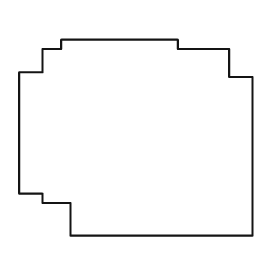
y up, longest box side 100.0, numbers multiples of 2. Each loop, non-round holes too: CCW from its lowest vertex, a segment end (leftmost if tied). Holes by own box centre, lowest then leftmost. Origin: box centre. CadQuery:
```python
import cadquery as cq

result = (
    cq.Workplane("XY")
    .moveTo(-28.0, -42.0)
    .lineTo(50.0, -42.0)
    .lineTo(50.0, 26.0)
    .lineTo(40.0, 26.0)
    .lineTo(40.0, 38.0)
    .lineTo(18.0, 38.0)
    .lineTo(18.0, 42.0)
    .lineTo(-32.0, 42.0)
    .lineTo(-32.0, 38.0)
    .lineTo(-40.0, 38.0)
    .lineTo(-40.0, 28.0)
    .lineTo(-50.0, 28.0)
    .lineTo(-50.0, -24.0)
    .lineTo(-40.0, -24.0)
    .lineTo(-40.0, -28.0)
    .lineTo(-28.0, -28.0)
    .close()
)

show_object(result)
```